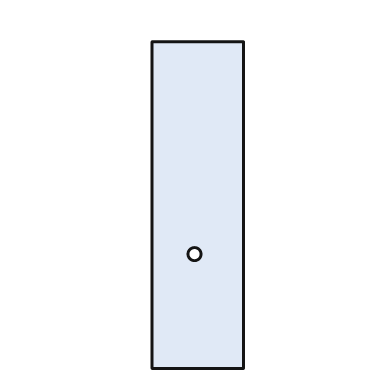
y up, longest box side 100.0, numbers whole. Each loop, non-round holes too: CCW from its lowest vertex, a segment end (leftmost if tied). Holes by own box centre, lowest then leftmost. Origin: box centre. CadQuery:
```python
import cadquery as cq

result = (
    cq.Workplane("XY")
    .moveTo(-14.0, -50.0)
    .lineTo(14.0, -50.0)
    .lineTo(14.0, 50.0)
    .lineTo(-14.0, 50.0)
    .close()
    .moveTo(-1.0, -15.0)
    .circle(2.0)
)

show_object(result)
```